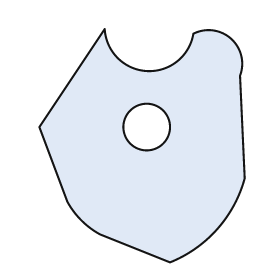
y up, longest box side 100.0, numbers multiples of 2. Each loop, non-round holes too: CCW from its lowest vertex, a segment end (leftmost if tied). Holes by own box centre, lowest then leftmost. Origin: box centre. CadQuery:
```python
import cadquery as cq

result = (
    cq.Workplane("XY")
    .moveTo(12.0, -50.0)
    .threePointArc((32.0, -36.0), (44.0, -14.0))
    .lineTo(42.0, 30.0)
    .threePointArc((38.0, 46.0), (22.0, 48.0))
    .threePointArc((2.0, 32.0), (-16.0, 50.0))
    .lineTo(-44.0, 8.0)
    .lineTo(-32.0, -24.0)
    .threePointArc((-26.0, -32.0), (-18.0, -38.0))
    .close()
    .moveTo(2.0, 8.0)
    .circle(10.0)
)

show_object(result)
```